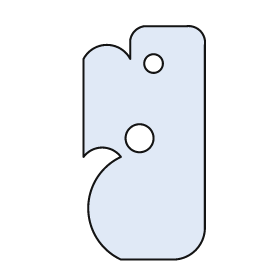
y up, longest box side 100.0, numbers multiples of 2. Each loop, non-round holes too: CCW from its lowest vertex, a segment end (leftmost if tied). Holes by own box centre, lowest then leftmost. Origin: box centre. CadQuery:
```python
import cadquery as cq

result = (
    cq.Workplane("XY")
    .moveTo(-10.0, -50.0)
    .lineTo(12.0, -50.0)
    .threePointArc((22.0, -46.0), (26.0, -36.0))
    .lineTo(26.0, 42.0)
    .threePointArc((24.0, 48.0), (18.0, 50.0))
    .lineTo(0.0, 50.0)
    .threePointArc((-4.0, 48.0), (-6.0, 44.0))
    .lineTo(-6.0, 36.0)
    .threePointArc((-16.0, 42.0), (-26.0, 36.0))
    .lineTo(-26.0, -6.0)
    .threePointArc((-18.0, -2.0), (-10.0, -6.0))
    .threePointArc((-24.0, -28.0), (-10.0, -50.0))
    .close()
    .moveTo(-2.0, 2.0)
    .circle(6.0)
    .moveTo(4.0, 34.0)
    .circle(4.0)
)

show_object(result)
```